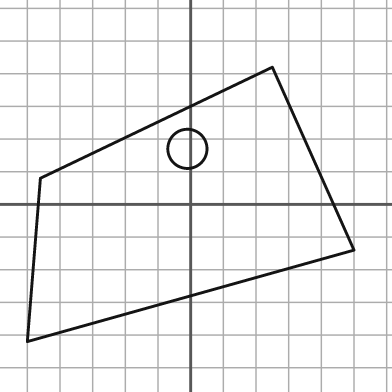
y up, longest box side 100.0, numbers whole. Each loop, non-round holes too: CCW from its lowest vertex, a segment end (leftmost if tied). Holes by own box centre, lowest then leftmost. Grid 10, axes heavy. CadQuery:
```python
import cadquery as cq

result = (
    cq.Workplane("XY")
    .moveTo(-50.0, -42.0)
    .lineTo(50.0, -14.0)
    .lineTo(25.0, 42.0)
    .lineTo(-46.0, 8.0)
    .close()
    .moveTo(-1.0, 17.0)
    .circle(6.0)
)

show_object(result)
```